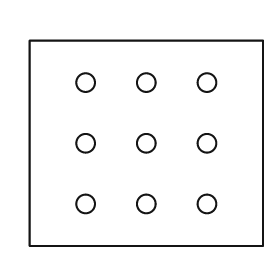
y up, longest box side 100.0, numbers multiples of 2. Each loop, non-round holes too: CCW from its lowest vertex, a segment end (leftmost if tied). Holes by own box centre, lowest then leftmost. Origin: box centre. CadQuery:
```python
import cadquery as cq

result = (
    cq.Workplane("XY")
    .moveTo(-50.0, -44.0)
    .lineTo(50.0, -44.0)
    .lineTo(50.0, 44.0)
    .lineTo(-50.0, 44.0)
    .close()
    .moveTo(-26.0, -26.0)
    .circle(4.0)
    .moveTo(0.0, -26.0)
    .circle(4.0)
    .moveTo(26.0, -26.0)
    .circle(4.0)
    .moveTo(-26.0, 0.0)
    .circle(4.0)
    .moveTo(0.0, 0.0)
    .circle(4.0)
    .moveTo(26.0, 0.0)
    .circle(4.0)
    .moveTo(-26.0, 26.0)
    .circle(4.0)
    .moveTo(0.0, 26.0)
    .circle(4.0)
    .moveTo(26.0, 26.0)
    .circle(4.0)
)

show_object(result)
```